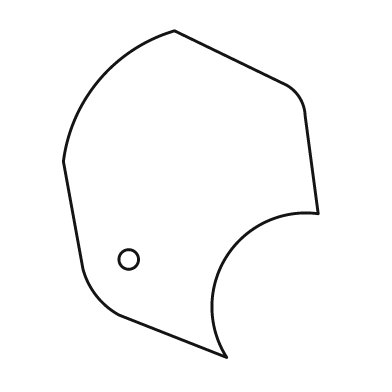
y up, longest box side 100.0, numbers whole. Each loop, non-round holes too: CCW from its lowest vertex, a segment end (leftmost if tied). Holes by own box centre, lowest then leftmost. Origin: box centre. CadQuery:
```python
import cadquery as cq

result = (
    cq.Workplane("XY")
    .moveTo(11.0, -50.0)
    .threePointArc((11.0, -19.0), (39.0, -6.0))
    .lineTo(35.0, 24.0)
    .threePointArc((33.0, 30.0), (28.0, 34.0))
    .lineTo(-5.0, 50.0)
    .threePointArc((-28.0, 35.0), (-39.0, 10.0))
    .lineTo(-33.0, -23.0)
    .threePointArc((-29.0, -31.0), (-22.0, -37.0))
    .close()
    .moveTo(-19.0, -20.0)
    .circle(3.0)
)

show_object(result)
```